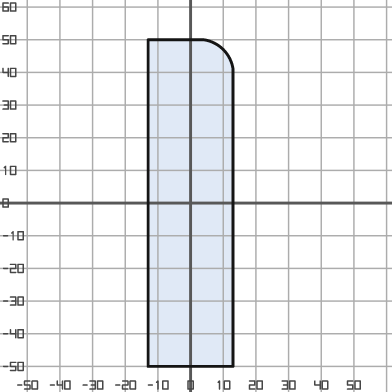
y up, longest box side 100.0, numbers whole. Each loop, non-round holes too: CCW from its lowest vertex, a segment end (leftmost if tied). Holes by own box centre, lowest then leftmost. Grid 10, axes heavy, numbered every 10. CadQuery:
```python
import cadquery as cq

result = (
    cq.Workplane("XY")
    .moveTo(-13.0, -50.0)
    .lineTo(13.0, -50.0)
    .lineTo(13.0, 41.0)
    .threePointArc((10.0, 47.0), (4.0, 50.0))
    .lineTo(-13.0, 50.0)
    .close()
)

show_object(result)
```